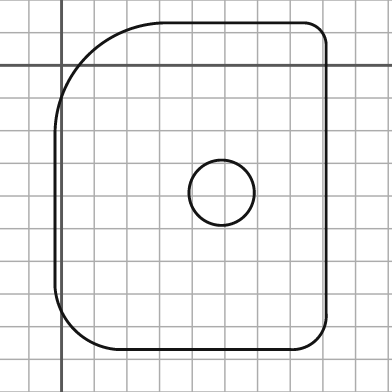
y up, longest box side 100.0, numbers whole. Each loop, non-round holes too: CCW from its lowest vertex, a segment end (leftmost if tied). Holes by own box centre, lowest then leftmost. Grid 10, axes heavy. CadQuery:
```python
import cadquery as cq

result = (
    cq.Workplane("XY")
    .moveTo(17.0, -87.0)
    .lineTo(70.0, -87.0)
    .threePointArc((78.0, -84.0), (81.0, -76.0))
    .lineTo(81.0, 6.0)
    .threePointArc((79.0, 11.0), (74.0, 13.0))
    .lineTo(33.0, 13.0)
    .threePointArc((8.0, 3.0), (-2.0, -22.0))
    .lineTo(-2.0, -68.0)
    .threePointArc((4.0, -81.0), (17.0, -87.0))
    .close()
    .moveTo(49.0, -39.0)
    .circle(10.0)
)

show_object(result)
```